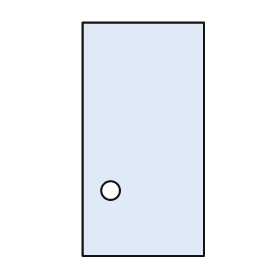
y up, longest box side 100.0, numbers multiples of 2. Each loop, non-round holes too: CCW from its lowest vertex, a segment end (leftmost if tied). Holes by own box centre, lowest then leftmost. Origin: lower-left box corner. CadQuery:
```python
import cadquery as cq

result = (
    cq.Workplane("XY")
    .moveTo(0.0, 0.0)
    .lineTo(52.0, 0.0)
    .lineTo(52.0, 100.0)
    .lineTo(0.0, 100.0)
    .close()
    .moveTo(12.0, 28.0)
    .circle(4.0)
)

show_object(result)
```